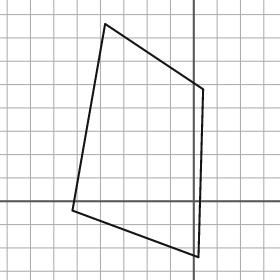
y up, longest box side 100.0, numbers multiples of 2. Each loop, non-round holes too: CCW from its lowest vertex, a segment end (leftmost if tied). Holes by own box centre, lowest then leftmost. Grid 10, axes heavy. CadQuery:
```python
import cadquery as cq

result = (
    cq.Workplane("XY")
    .moveTo(2.0, -24.0)
    .lineTo(4.0, 48.0)
    .lineTo(-38.0, 76.0)
    .lineTo(-52.0, -4.0)
    .close()
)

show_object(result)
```